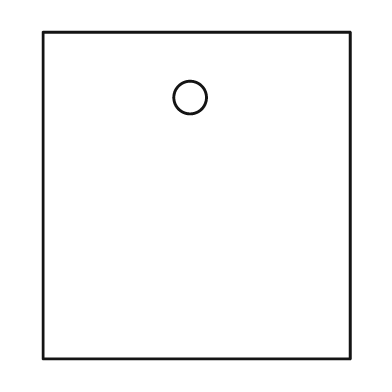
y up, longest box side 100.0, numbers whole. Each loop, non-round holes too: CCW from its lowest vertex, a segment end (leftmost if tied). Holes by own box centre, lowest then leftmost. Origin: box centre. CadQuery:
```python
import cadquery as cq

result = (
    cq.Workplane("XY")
    .moveTo(-47.0, -50.0)
    .lineTo(47.0, -50.0)
    .lineTo(47.0, 50.0)
    .lineTo(-47.0, 50.0)
    .close()
    .moveTo(-2.0, 30.0)
    .circle(5.0)
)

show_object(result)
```